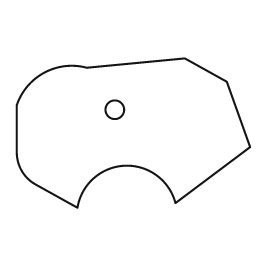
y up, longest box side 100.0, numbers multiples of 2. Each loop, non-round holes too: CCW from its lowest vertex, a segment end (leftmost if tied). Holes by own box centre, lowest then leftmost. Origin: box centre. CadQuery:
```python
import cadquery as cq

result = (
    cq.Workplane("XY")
    .moveTo(-24.0, -32.0)
    .threePointArc((-4.0, -14.0), (18.0, -30.0))
    .lineTo(50.0, -6.0)
    .lineTo(40.0, 22.0)
    .lineTo(22.0, 32.0)
    .lineTo(-20.0, 28.0)
    .threePointArc((-38.0, 26.0), (-50.0, 12.0))
    .lineTo(-50.0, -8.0)
    .threePointArc((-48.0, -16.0), (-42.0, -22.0))
    .close()
    .moveTo(-8.0, 10.0)
    .circle(4.0)
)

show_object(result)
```